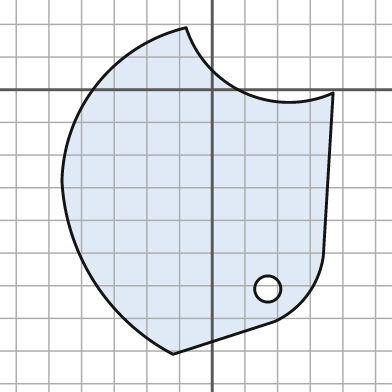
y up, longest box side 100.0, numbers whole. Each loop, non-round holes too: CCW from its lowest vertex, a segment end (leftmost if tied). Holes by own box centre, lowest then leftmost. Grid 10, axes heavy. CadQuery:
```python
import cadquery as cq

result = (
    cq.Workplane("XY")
    .moveTo(-12.0, -81.0)
    .lineTo(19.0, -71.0)
    .threePointArc((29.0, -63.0), (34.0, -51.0))
    .lineTo(37.0, -1.0)
    .threePointArc((10.0, -1.0), (-8.0, 19.0))
    .threePointArc((-35.0, 2.0), (-46.0, -28.0))
    .threePointArc((-36.0, -59.0), (-12.0, -81.0))
    .close()
    .moveTo(17.0, -61.0)
    .circle(4.0)
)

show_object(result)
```